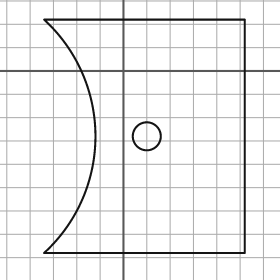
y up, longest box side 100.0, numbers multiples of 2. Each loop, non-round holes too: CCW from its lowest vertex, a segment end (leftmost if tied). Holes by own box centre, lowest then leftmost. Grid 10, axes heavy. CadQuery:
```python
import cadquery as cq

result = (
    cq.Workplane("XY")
    .moveTo(-34.0, -78.0)
    .lineTo(52.0, -78.0)
    .lineTo(52.0, 22.0)
    .lineTo(-34.0, 22.0)
    .threePointArc((-12.0, -28.0), (-34.0, -78.0))
    .close()
    .moveTo(10.0, -28.0)
    .circle(6.0)
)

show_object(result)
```